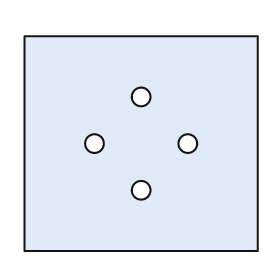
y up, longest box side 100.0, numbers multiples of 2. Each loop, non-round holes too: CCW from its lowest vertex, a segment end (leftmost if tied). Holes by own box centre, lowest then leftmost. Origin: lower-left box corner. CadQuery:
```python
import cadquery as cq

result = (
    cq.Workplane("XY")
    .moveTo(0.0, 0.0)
    .lineTo(100.0, 0.0)
    .lineTo(100.0, 92.0)
    .lineTo(0.0, 92.0)
    .close()
    .moveTo(50.0, 26.0)
    .circle(4.0)
    .moveTo(30.0, 46.0)
    .circle(4.0)
    .moveTo(70.0, 46.0)
    .circle(4.0)
    .moveTo(50.0, 66.0)
    .circle(4.0)
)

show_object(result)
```